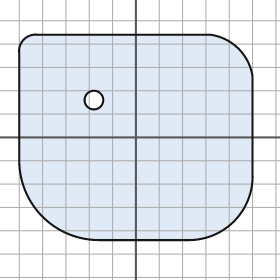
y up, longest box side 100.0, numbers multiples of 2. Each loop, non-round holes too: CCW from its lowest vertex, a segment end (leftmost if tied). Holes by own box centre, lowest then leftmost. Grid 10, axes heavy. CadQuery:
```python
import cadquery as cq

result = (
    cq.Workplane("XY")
    .moveTo(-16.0, -44.0)
    .lineTo(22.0, -44.0)
    .threePointArc((42.0, -36.0), (50.0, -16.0))
    .lineTo(50.0, 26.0)
    .threePointArc((44.0, 38.0), (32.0, 44.0))
    .lineTo(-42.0, 44.0)
    .threePointArc((-48.0, 42.0), (-50.0, 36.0))
    .lineTo(-50.0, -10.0)
    .threePointArc((-40.0, -34.0), (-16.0, -44.0))
    .close()
    .moveTo(-18.0, 16.0)
    .circle(4.0)
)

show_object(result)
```